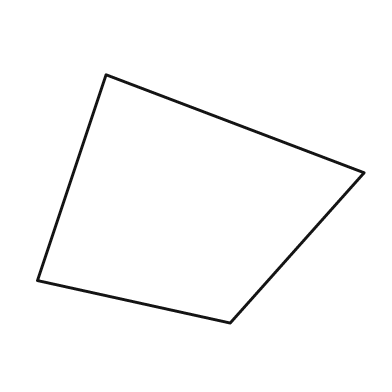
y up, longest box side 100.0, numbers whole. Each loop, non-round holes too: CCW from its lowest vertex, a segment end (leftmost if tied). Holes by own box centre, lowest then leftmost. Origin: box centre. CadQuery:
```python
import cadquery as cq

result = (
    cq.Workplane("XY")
    .moveTo(9.0, -38.0)
    .lineTo(50.0, 8.0)
    .lineTo(-29.0, 38.0)
    .lineTo(-50.0, -25.0)
    .close()
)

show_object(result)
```